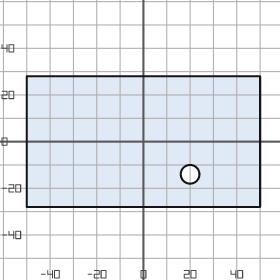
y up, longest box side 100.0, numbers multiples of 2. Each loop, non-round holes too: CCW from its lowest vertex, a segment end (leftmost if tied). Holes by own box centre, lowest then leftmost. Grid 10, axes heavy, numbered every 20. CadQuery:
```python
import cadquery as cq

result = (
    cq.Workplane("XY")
    .moveTo(-50.0, -28.0)
    .lineTo(50.0, -28.0)
    .lineTo(50.0, 28.0)
    .lineTo(-50.0, 28.0)
    .close()
    .moveTo(20.0, -14.0)
    .circle(4.0)
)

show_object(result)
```